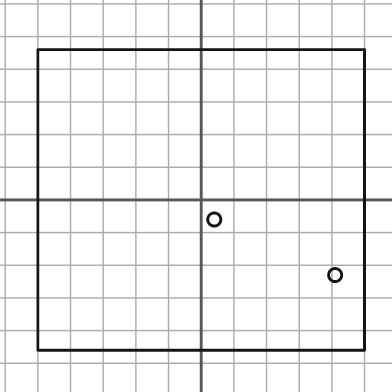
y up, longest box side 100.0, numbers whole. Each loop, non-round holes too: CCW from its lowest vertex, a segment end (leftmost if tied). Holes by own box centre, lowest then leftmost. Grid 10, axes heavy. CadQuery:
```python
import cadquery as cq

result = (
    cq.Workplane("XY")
    .moveTo(-50.0, -46.0)
    .lineTo(50.0, -46.0)
    .lineTo(50.0, 46.0)
    .lineTo(-50.0, 46.0)
    .close()
    .moveTo(41.0, -23.0)
    .circle(2.0)
    .moveTo(4.0, -6.0)
    .circle(2.0)
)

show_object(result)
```